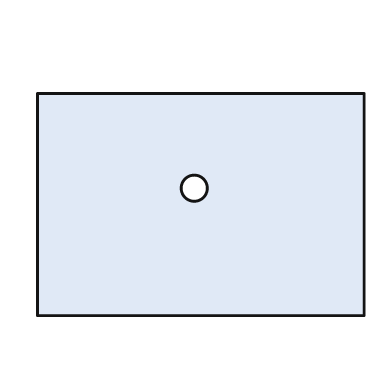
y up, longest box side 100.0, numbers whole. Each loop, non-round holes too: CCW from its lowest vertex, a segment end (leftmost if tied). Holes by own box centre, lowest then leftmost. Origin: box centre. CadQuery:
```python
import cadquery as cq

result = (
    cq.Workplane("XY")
    .moveTo(-50.0, -34.0)
    .lineTo(50.0, -34.0)
    .lineTo(50.0, 34.0)
    .lineTo(-50.0, 34.0)
    .close()
    .moveTo(-2.0, 5.0)
    .circle(4.0)
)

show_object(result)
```